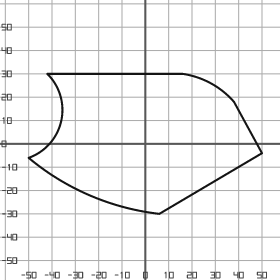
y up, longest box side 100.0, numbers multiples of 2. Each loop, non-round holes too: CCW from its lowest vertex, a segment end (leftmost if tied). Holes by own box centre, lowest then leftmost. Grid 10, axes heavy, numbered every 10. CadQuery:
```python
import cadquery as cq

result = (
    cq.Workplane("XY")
    .moveTo(6.0, -30.0)
    .lineTo(50.0, -4.0)
    .lineTo(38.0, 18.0)
    .threePointArc((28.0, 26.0), (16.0, 30.0))
    .lineTo(-42.0, 30.0)
    .threePointArc((-36.0, 10.0), (-50.0, -6.0))
    .threePointArc((-24.0, -22.0), (6.0, -30.0))
    .close()
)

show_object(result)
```